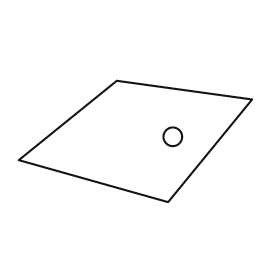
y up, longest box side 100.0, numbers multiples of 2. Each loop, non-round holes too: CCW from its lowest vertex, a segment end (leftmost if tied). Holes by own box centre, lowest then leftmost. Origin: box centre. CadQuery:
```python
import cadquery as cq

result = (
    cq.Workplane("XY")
    .moveTo(14.0, -26.0)
    .lineTo(50.0, 18.0)
    .lineTo(-8.0, 26.0)
    .lineTo(-50.0, -8.0)
    .close()
    .moveTo(16.0, 2.0)
    .circle(4.0)
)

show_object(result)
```